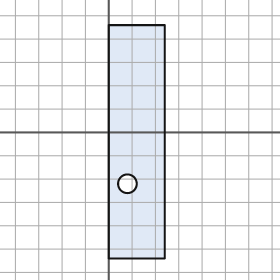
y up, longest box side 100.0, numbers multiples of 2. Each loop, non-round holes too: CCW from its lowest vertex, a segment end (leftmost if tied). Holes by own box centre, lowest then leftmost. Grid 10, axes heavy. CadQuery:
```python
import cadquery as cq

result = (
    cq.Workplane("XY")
    .moveTo(0.0, -54.0)
    .lineTo(24.0, -54.0)
    .lineTo(24.0, 46.0)
    .lineTo(0.0, 46.0)
    .close()
    .moveTo(8.0, -22.0)
    .circle(4.0)
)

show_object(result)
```